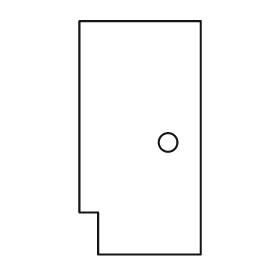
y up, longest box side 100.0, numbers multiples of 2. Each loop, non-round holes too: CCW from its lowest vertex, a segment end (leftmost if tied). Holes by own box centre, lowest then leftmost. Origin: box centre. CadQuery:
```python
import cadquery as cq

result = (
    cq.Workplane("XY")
    .moveTo(-18.0, -50.0)
    .lineTo(26.0, -50.0)
    .lineTo(26.0, 50.0)
    .lineTo(-26.0, 50.0)
    .lineTo(-26.0, -32.0)
    .lineTo(-18.0, -32.0)
    .close()
    .moveTo(12.0, -2.0)
    .circle(4.0)
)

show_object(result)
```